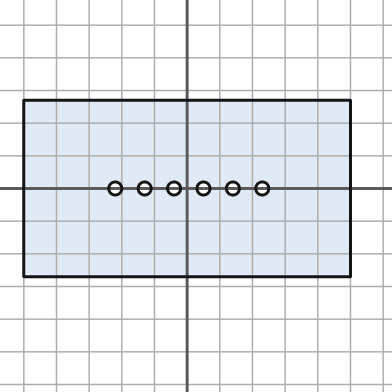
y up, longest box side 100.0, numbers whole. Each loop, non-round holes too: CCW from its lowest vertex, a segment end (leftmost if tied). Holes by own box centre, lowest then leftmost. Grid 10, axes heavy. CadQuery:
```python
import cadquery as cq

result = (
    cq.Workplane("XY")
    .moveTo(-50.0, -27.0)
    .lineTo(50.0, -27.0)
    .lineTo(50.0, 27.0)
    .lineTo(-50.0, 27.0)
    .close()
    .moveTo(-22.0, 0.0)
    .circle(2.0)
    .moveTo(-13.0, 0.0)
    .circle(2.0)
    .moveTo(-4.0, 0.0)
    .circle(2.0)
    .moveTo(5.0, 0.0)
    .circle(2.0)
    .moveTo(14.0, 0.0)
    .circle(2.0)
    .moveTo(23.0, 0.0)
    .circle(2.0)
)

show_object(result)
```